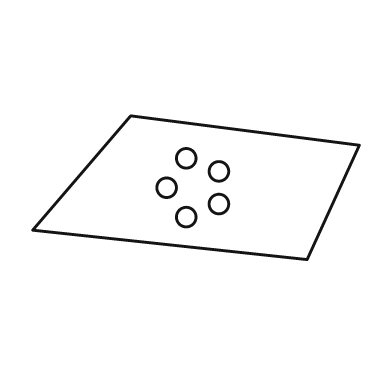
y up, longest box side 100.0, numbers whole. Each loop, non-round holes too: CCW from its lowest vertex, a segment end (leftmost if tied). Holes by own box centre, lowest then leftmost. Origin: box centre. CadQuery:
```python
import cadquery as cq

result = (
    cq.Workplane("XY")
    .moveTo(34.0, -22.0)
    .lineTo(50.0, 13.0)
    .lineTo(-20.0, 22.0)
    .lineTo(-50.0, -13.0)
    .close()
    .moveTo(-3.0, -9.0)
    .circle(3.0)
    .moveTo(7.0, -5.0)
    .circle(3.0)
    .moveTo(-9.0, 0.0)
    .circle(3.0)
    .moveTo(7.0, 5.0)
    .circle(3.0)
    .moveTo(-3.0, 9.0)
    .circle(3.0)
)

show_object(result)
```